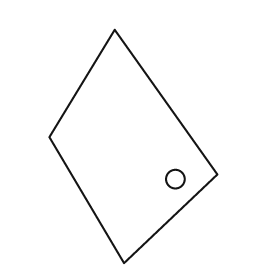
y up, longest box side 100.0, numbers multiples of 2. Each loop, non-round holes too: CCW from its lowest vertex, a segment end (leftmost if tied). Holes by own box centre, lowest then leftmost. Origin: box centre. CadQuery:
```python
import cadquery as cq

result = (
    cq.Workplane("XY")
    .moveTo(-4.0, -50.0)
    .lineTo(36.0, -12.0)
    .lineTo(-8.0, 50.0)
    .lineTo(-36.0, 4.0)
    .close()
    .moveTo(18.0, -14.0)
    .circle(4.0)
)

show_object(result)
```